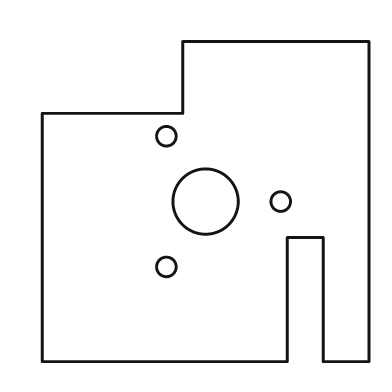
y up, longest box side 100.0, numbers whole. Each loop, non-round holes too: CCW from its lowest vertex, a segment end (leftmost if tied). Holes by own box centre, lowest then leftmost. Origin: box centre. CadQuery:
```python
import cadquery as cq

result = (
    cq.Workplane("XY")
    .moveTo(-50.0, -49.0)
    .lineTo(25.0, -49.0)
    .lineTo(25.0, -11.0)
    .lineTo(36.0, -11.0)
    .lineTo(36.0, -49.0)
    .lineTo(50.0, -49.0)
    .lineTo(50.0, 49.0)
    .lineTo(-7.0, 49.0)
    .lineTo(-7.0, 27.0)
    .lineTo(-50.0, 27.0)
    .close()
    .moveTo(-12.0, -20.0)
    .circle(3.0)
    .moveTo(0.0, 0.0)
    .circle(10.0)
    .moveTo(23.0, 0.0)
    .circle(3.0)
    .moveTo(-12.0, 20.0)
    .circle(3.0)
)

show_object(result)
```